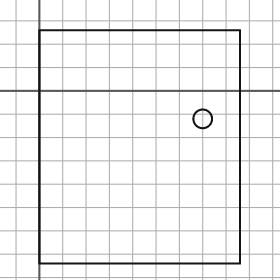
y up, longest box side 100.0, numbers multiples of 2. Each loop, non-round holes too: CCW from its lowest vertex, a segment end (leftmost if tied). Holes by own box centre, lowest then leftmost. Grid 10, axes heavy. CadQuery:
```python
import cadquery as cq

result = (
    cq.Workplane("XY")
    .moveTo(0.0, -74.0)
    .lineTo(86.0, -74.0)
    .lineTo(86.0, 26.0)
    .lineTo(0.0, 26.0)
    .close()
    .moveTo(70.0, -12.0)
    .circle(4.0)
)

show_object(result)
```